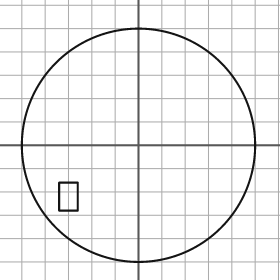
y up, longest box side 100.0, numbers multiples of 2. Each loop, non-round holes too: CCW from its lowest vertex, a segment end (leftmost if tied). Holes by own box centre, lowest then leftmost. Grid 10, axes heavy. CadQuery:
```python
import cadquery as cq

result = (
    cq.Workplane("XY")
    .moveTo(0.0, 0.0)
    .circle(50.0)
    .moveTo(-34.0, -28.0)
    .lineTo(-26.0, -28.0)
    .lineTo(-26.0, -16.0)
    .lineTo(-34.0, -16.0)
    .close()
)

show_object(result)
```